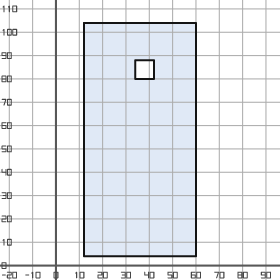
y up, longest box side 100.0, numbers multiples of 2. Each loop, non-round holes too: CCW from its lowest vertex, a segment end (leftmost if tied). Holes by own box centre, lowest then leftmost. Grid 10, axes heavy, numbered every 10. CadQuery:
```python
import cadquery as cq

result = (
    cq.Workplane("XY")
    .moveTo(12.0, 4.0)
    .lineTo(60.0, 4.0)
    .lineTo(60.0, 104.0)
    .lineTo(12.0, 104.0)
    .close()
    .moveTo(34.0, 80.0)
    .lineTo(42.0, 80.0)
    .lineTo(42.0, 88.0)
    .lineTo(34.0, 88.0)
    .close()
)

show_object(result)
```